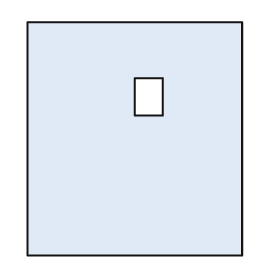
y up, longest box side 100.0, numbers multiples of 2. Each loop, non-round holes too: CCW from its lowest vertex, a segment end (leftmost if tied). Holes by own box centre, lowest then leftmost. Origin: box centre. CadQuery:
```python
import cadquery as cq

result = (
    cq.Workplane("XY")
    .moveTo(-46.0, -50.0)
    .lineTo(46.0, -50.0)
    .lineTo(46.0, 50.0)
    .lineTo(-46.0, 50.0)
    .close()
    .moveTo(0.0, 10.0)
    .lineTo(12.0, 10.0)
    .lineTo(12.0, 26.0)
    .lineTo(0.0, 26.0)
    .close()
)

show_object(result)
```